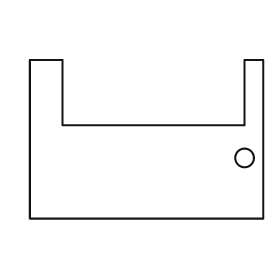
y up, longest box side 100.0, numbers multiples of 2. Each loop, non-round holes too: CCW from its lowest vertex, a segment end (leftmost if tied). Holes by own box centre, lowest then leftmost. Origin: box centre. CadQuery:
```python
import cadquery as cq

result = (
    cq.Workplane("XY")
    .moveTo(-50.0, -34.0)
    .lineTo(50.0, -34.0)
    .lineTo(50.0, 34.0)
    .lineTo(42.0, 34.0)
    .lineTo(42.0, 6.0)
    .lineTo(-36.0, 6.0)
    .lineTo(-36.0, 34.0)
    .lineTo(-50.0, 34.0)
    .close()
    .moveTo(42.0, -8.0)
    .circle(4.0)
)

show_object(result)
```